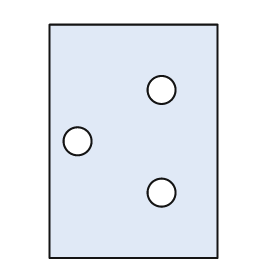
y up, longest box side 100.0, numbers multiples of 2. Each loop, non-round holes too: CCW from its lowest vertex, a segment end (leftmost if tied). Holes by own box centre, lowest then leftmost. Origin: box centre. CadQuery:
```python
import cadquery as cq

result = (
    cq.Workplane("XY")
    .moveTo(-36.0, -50.0)
    .lineTo(36.0, -50.0)
    .lineTo(36.0, 50.0)
    .lineTo(-36.0, 50.0)
    .close()
    .moveTo(12.0, -22.0)
    .circle(6.0)
    .moveTo(-24.0, 0.0)
    .circle(6.0)
    .moveTo(12.0, 22.0)
    .circle(6.0)
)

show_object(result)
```